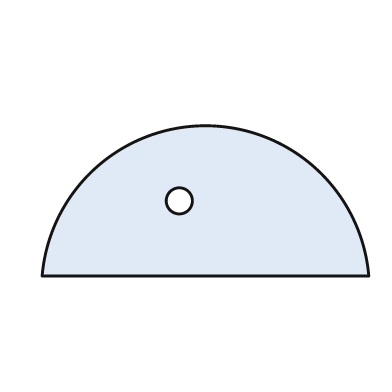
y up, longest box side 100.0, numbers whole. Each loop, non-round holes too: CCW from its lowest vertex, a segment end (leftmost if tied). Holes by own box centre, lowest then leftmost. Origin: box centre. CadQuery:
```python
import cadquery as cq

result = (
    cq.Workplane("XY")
    .moveTo(-50.0, -23.0)
    .lineTo(50.0, -23.0)
    .threePointArc((0.0, 23.0), (-50.0, -23.0))
    .close()
    .moveTo(-8.0, 0.0)
    .circle(4.0)
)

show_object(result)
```